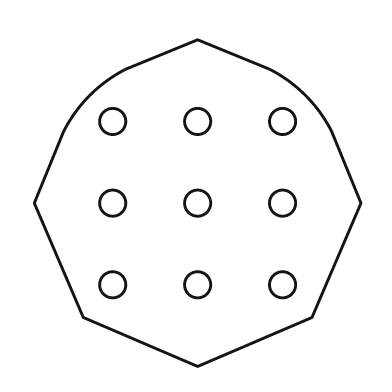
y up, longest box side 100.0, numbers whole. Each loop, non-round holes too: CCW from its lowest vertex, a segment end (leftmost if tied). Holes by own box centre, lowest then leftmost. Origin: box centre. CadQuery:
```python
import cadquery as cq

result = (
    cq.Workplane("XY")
    .moveTo(0.0, -50.0)
    .lineTo(35.0, -35.0)
    .lineTo(50.0, 0.0)
    .lineTo(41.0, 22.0)
    .threePointArc((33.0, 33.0), (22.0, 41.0))
    .lineTo(0.0, 50.0)
    .lineTo(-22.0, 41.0)
    .threePointArc((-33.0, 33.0), (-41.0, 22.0))
    .lineTo(-50.0, 0.0)
    .lineTo(-35.0, -35.0)
    .close()
    .moveTo(-26.0, -25.0)
    .circle(4.0)
    .moveTo(0.0, -25.0)
    .circle(4.0)
    .moveTo(26.0, -25.0)
    .circle(4.0)
    .moveTo(-26.0, 0.0)
    .circle(4.0)
    .moveTo(0.0, 0.0)
    .circle(4.0)
    .moveTo(26.0, 0.0)
    .circle(4.0)
    .moveTo(-26.0, 25.0)
    .circle(4.0)
    .moveTo(0.0, 25.0)
    .circle(4.0)
    .moveTo(26.0, 25.0)
    .circle(4.0)
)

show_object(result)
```